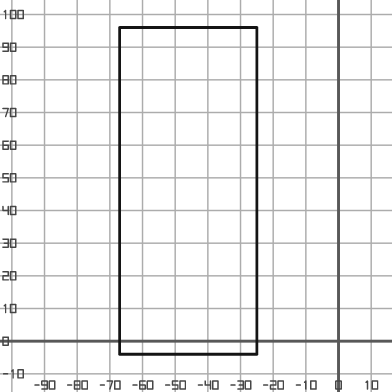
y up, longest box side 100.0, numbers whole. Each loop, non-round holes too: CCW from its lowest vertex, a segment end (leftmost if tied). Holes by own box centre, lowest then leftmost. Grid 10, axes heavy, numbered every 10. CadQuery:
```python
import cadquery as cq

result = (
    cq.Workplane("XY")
    .moveTo(-67.0, -4.0)
    .lineTo(-25.0, -4.0)
    .lineTo(-25.0, 96.0)
    .lineTo(-67.0, 96.0)
    .close()
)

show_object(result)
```